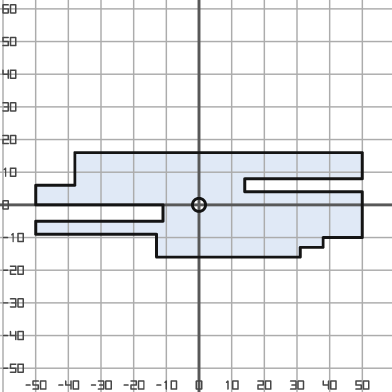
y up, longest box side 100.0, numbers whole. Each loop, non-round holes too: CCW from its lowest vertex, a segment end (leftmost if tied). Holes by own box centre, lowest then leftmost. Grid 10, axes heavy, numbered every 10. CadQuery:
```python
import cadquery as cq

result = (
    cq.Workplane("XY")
    .moveTo(-13.0, -16.0)
    .lineTo(31.0, -16.0)
    .lineTo(31.0, -13.0)
    .lineTo(38.0, -13.0)
    .lineTo(38.0, -10.0)
    .lineTo(50.0, -10.0)
    .lineTo(50.0, 4.0)
    .lineTo(14.0, 4.0)
    .lineTo(14.0, 8.0)
    .lineTo(50.0, 8.0)
    .lineTo(50.0, 16.0)
    .lineTo(-38.0, 16.0)
    .lineTo(-38.0, 6.0)
    .lineTo(-50.0, 6.0)
    .lineTo(-50.0, 0.0)
    .lineTo(-11.0, 0.0)
    .lineTo(-11.0, -5.0)
    .lineTo(-50.0, -5.0)
    .lineTo(-50.0, -9.0)
    .lineTo(-13.0, -9.0)
    .close()
    .moveTo(0.0, 0.0)
    .circle(2.0)
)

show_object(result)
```